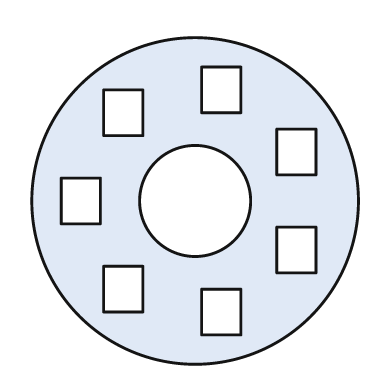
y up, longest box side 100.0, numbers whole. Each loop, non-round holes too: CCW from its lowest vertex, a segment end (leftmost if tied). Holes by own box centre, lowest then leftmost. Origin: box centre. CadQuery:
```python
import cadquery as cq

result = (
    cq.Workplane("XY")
    .moveTo(0.0, 0.0)
    .circle(50.0)
    .moveTo(2.0, -41.0)
    .lineTo(14.0, -41.0)
    .lineTo(14.0, -27.0)
    .lineTo(2.0, -27.0)
    .close()
    .moveTo(-28.0, -34.0)
    .lineTo(-16.0, -34.0)
    .lineTo(-16.0, -20.0)
    .lineTo(-28.0, -20.0)
    .close()
    .moveTo(25.0, -22.0)
    .lineTo(37.0, -22.0)
    .lineTo(37.0, -8.0)
    .lineTo(25.0, -8.0)
    .close()
    .moveTo(-41.0, -7.0)
    .lineTo(-29.0, -7.0)
    .lineTo(-29.0, 7.0)
    .lineTo(-41.0, 7.0)
    .close()
    .moveTo(0.0, 0.0)
    .circle(17.0)
    .moveTo(25.0, 8.0)
    .lineTo(37.0, 8.0)
    .lineTo(37.0, 22.0)
    .lineTo(25.0, 22.0)
    .close()
    .moveTo(-28.0, 20.0)
    .lineTo(-16.0, 20.0)
    .lineTo(-16.0, 34.0)
    .lineTo(-28.0, 34.0)
    .close()
    .moveTo(2.0, 27.0)
    .lineTo(14.0, 27.0)
    .lineTo(14.0, 41.0)
    .lineTo(2.0, 41.0)
    .close()
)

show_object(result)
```